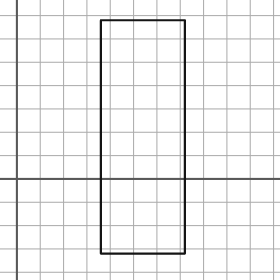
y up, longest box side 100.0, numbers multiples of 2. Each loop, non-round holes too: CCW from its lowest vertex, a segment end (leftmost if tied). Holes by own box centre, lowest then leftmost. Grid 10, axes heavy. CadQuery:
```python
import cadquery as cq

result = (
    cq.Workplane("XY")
    .moveTo(36.0, -32.0)
    .lineTo(72.0, -32.0)
    .lineTo(72.0, 68.0)
    .lineTo(36.0, 68.0)
    .close()
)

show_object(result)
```